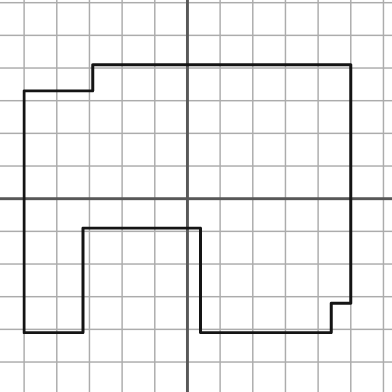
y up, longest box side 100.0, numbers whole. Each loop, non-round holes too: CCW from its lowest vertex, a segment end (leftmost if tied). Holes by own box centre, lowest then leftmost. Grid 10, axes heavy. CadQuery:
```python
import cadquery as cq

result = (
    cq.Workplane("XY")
    .moveTo(-50.0, -41.0)
    .lineTo(-32.0, -41.0)
    .lineTo(-32.0, -9.0)
    .lineTo(4.0, -9.0)
    .lineTo(4.0, -41.0)
    .lineTo(44.0, -41.0)
    .lineTo(44.0, -32.0)
    .lineTo(50.0, -32.0)
    .lineTo(50.0, 41.0)
    .lineTo(-29.0, 41.0)
    .lineTo(-29.0, 33.0)
    .lineTo(-50.0, 33.0)
    .close()
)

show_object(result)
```